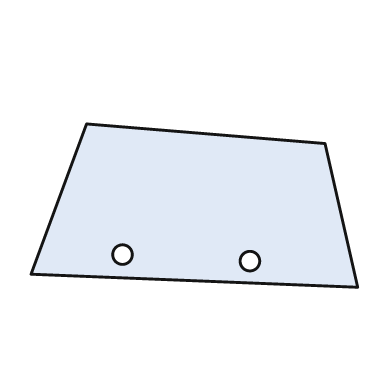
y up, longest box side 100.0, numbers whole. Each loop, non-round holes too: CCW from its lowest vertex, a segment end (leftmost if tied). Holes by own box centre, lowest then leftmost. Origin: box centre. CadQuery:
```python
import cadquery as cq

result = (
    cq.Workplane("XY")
    .moveTo(50.0, -25.0)
    .lineTo(40.0, 19.0)
    .lineTo(-33.0, 25.0)
    .lineTo(-50.0, -21.0)
    .close()
    .moveTo(17.0, -17.0)
    .circle(3.0)
    .moveTo(-22.0, -15.0)
    .circle(3.0)
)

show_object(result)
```